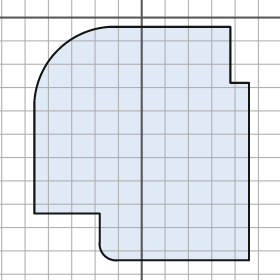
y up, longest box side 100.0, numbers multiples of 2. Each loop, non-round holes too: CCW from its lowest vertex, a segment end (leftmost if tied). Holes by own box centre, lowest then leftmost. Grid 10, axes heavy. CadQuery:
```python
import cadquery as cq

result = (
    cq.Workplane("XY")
    .moveTo(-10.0, -104.0)
    .lineTo(46.0, -104.0)
    .lineTo(46.0, -28.0)
    .lineTo(38.0, -28.0)
    .lineTo(38.0, -4.0)
    .lineTo(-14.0, -4.0)
    .threePointArc((-36.0, -14.0), (-46.0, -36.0))
    .lineTo(-46.0, -84.0)
    .lineTo(-18.0, -84.0)
    .lineTo(-18.0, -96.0)
    .threePointArc((-16.0, -102.0), (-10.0, -104.0))
    .close()
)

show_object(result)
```